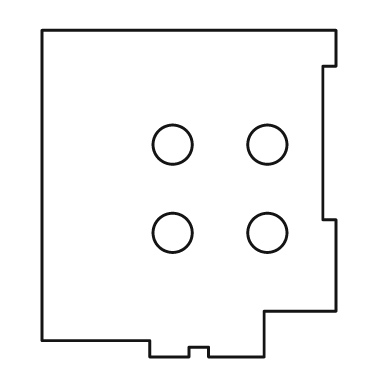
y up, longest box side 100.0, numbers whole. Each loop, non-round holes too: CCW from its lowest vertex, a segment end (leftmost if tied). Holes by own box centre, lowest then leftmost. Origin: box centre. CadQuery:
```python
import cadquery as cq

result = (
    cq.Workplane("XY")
    .moveTo(-12.0, -50.0)
    .lineTo(0.0, -50.0)
    .lineTo(0.0, -47.0)
    .lineTo(6.0, -47.0)
    .lineTo(6.0, -50.0)
    .lineTo(23.0, -50.0)
    .lineTo(23.0, -36.0)
    .lineTo(45.0, -36.0)
    .lineTo(45.0, -8.0)
    .lineTo(41.0, -8.0)
    .lineTo(41.0, 39.0)
    .lineTo(45.0, 39.0)
    .lineTo(45.0, 50.0)
    .lineTo(-45.0, 50.0)
    .lineTo(-45.0, -45.0)
    .lineTo(-12.0, -45.0)
    .close()
    .moveTo(-5.0, -12.0)
    .circle(6.0)
    .moveTo(24.0, -12.0)
    .circle(6.0)
    .moveTo(-5.0, 15.0)
    .circle(6.0)
    .moveTo(24.0, 15.0)
    .circle(6.0)
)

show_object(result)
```